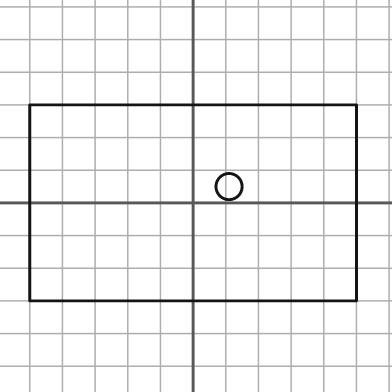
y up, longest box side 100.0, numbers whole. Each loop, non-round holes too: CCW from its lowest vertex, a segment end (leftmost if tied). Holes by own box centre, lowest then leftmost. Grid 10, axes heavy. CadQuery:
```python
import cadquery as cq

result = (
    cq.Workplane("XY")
    .moveTo(-50.0, -30.0)
    .lineTo(50.0, -30.0)
    .lineTo(50.0, 30.0)
    .lineTo(-50.0, 30.0)
    .close()
    .moveTo(11.0, 5.0)
    .circle(4.0)
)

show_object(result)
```